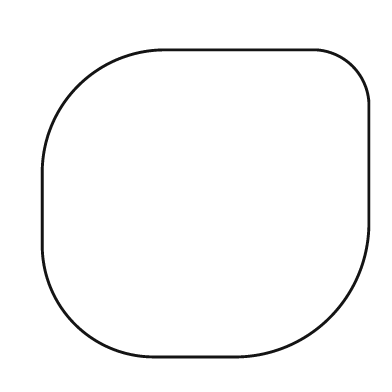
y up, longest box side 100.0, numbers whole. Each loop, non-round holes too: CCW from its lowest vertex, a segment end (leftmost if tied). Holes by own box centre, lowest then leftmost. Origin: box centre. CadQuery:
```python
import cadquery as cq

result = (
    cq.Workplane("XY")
    .moveTo(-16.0, -47.0)
    .lineTo(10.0, -47.0)
    .threePointArc((38.0, -35.0), (50.0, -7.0))
    .lineTo(50.0, 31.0)
    .threePointArc((45.0, 42.0), (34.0, 47.0))
    .lineTo(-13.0, 47.0)
    .threePointArc((-39.0, 36.0), (-50.0, 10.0))
    .lineTo(-50.0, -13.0)
    .threePointArc((-40.0, -37.0), (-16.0, -47.0))
    .close()
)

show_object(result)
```